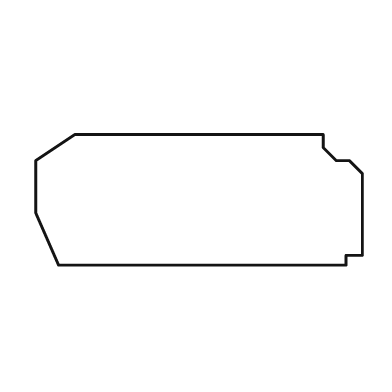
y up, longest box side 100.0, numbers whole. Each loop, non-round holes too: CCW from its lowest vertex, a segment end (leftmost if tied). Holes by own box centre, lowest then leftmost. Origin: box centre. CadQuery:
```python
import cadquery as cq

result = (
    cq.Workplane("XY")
    .moveTo(-43.0, -20.0)
    .lineTo(45.0, -20.0)
    .lineTo(45.0, -17.0)
    .lineTo(50.0, -17.0)
    .lineTo(50.0, 8.0)
    .lineTo(46.0, 12.0)
    .lineTo(42.0, 12.0)
    .lineTo(38.0, 16.0)
    .lineTo(38.0, 20.0)
    .lineTo(-38.0, 20.0)
    .lineTo(-50.0, 12.0)
    .lineTo(-50.0, -4.0)
    .close()
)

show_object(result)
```